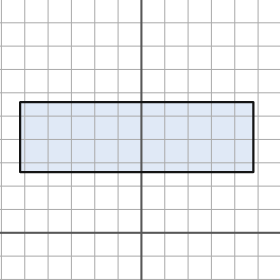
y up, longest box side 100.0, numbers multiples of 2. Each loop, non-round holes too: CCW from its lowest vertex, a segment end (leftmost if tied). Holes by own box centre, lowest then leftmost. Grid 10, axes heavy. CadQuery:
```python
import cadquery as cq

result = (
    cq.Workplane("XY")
    .moveTo(-52.0, 26.0)
    .lineTo(48.0, 26.0)
    .lineTo(48.0, 56.0)
    .lineTo(-52.0, 56.0)
    .close()
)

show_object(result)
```